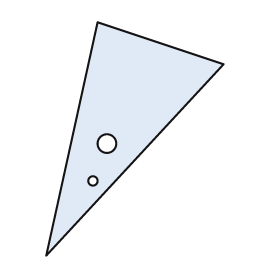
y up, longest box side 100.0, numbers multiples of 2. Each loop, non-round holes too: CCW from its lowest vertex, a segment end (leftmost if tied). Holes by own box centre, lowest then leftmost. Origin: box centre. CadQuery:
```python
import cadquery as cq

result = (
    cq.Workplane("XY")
    .moveTo(-38.0, -50.0)
    .lineTo(38.0, 32.0)
    .lineTo(-16.0, 50.0)
    .close()
    .moveTo(-18.0, -18.0)
    .circle(2.0)
    .moveTo(-12.0, -2.0)
    .circle(4.0)
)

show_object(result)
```